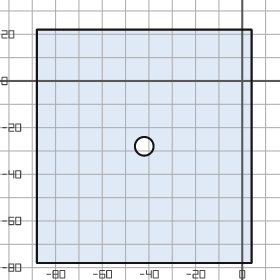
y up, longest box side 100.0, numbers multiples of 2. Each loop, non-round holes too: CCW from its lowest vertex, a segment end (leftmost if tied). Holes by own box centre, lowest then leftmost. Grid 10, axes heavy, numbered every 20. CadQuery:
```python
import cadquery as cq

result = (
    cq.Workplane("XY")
    .moveTo(-88.0, -78.0)
    .lineTo(4.0, -78.0)
    .lineTo(4.0, 22.0)
    .lineTo(-88.0, 22.0)
    .close()
    .moveTo(-42.0, -28.0)
    .circle(4.0)
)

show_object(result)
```